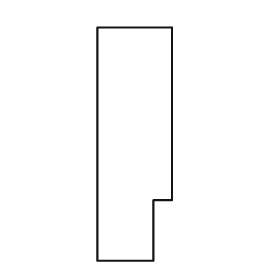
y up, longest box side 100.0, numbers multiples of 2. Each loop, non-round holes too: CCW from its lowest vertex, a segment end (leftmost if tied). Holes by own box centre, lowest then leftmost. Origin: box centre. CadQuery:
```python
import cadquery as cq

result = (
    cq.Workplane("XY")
    .moveTo(-16.0, -50.0)
    .lineTo(8.0, -50.0)
    .lineTo(8.0, -24.0)
    .lineTo(16.0, -24.0)
    .lineTo(16.0, 50.0)
    .lineTo(-16.0, 50.0)
    .close()
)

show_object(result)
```